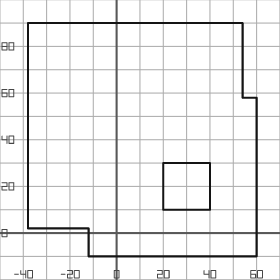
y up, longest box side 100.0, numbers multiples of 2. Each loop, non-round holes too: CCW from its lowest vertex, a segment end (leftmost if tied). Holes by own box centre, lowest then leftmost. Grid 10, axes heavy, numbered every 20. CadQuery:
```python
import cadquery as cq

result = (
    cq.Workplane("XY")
    .moveTo(-12.0, -10.0)
    .lineTo(60.0, -10.0)
    .lineTo(60.0, 58.0)
    .lineTo(54.0, 58.0)
    .lineTo(54.0, 90.0)
    .lineTo(-38.0, 90.0)
    .lineTo(-38.0, 2.0)
    .lineTo(-12.0, 2.0)
    .close()
    .moveTo(20.0, 10.0)
    .lineTo(40.0, 10.0)
    .lineTo(40.0, 30.0)
    .lineTo(20.0, 30.0)
    .close()
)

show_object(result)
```